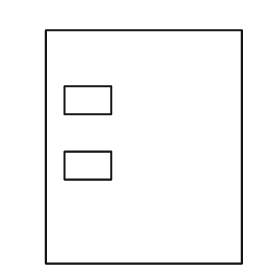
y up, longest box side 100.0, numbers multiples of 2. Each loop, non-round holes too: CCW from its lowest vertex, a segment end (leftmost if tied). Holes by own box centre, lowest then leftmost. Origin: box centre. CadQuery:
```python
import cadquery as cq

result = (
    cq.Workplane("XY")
    .moveTo(-42.0, -50.0)
    .lineTo(42.0, -50.0)
    .lineTo(42.0, 50.0)
    .lineTo(-42.0, 50.0)
    .close()
    .moveTo(-34.0, -14.0)
    .lineTo(-14.0, -14.0)
    .lineTo(-14.0, -2.0)
    .lineTo(-34.0, -2.0)
    .close()
    .moveTo(-34.0, 14.0)
    .lineTo(-14.0, 14.0)
    .lineTo(-14.0, 26.0)
    .lineTo(-34.0, 26.0)
    .close()
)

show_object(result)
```